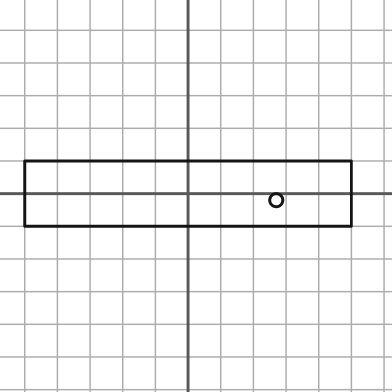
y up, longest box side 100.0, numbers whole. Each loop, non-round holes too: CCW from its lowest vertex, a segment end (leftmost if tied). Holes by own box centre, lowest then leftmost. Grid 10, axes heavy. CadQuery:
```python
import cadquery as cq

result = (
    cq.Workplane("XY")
    .moveTo(-50.0, -10.0)
    .lineTo(50.0, -10.0)
    .lineTo(50.0, 10.0)
    .lineTo(-50.0, 10.0)
    .close()
    .moveTo(27.0, -2.0)
    .circle(2.0)
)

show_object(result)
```